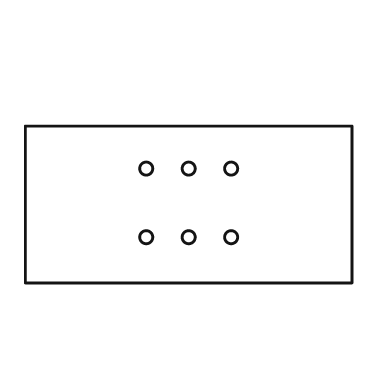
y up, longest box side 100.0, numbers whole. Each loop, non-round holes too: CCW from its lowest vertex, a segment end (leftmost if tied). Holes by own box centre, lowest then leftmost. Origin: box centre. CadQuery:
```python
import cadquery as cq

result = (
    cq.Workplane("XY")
    .moveTo(-50.0, -24.0)
    .lineTo(50.0, -24.0)
    .lineTo(50.0, 24.0)
    .lineTo(-50.0, 24.0)
    .close()
    .moveTo(-13.0, -10.0)
    .circle(2.0)
    .moveTo(0.0, -10.0)
    .circle(2.0)
    .moveTo(13.0, -10.0)
    .circle(2.0)
    .moveTo(-13.0, 11.0)
    .circle(2.0)
    .moveTo(0.0, 11.0)
    .circle(2.0)
    .moveTo(13.0, 11.0)
    .circle(2.0)
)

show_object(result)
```